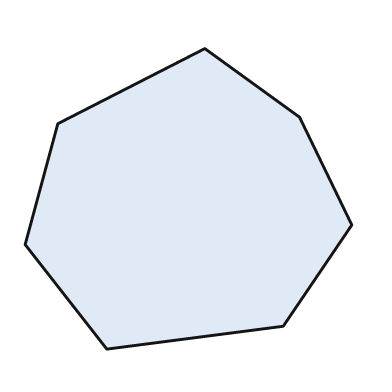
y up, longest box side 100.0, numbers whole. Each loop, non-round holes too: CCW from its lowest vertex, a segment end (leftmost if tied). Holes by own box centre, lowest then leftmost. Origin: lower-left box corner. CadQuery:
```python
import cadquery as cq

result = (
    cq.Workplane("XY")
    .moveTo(25.0, 0.0)
    .lineTo(79.0, 7.0)
    .lineTo(100.0, 38.0)
    .lineTo(84.0, 71.0)
    .lineTo(55.0, 92.0)
    .lineTo(10.0, 69.0)
    .lineTo(0.0, 32.0)
    .close()
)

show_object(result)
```